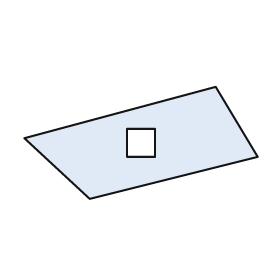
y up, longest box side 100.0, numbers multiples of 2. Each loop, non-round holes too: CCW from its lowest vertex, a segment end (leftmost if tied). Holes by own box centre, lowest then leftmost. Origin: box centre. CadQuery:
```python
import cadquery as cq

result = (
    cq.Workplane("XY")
    .moveTo(-22.0, -24.0)
    .lineTo(50.0, -6.0)
    .lineTo(32.0, 24.0)
    .lineTo(-50.0, 2.0)
    .close()
    .moveTo(-6.0, -6.0)
    .lineTo(6.0, -6.0)
    .lineTo(6.0, 6.0)
    .lineTo(-6.0, 6.0)
    .close()
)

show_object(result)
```